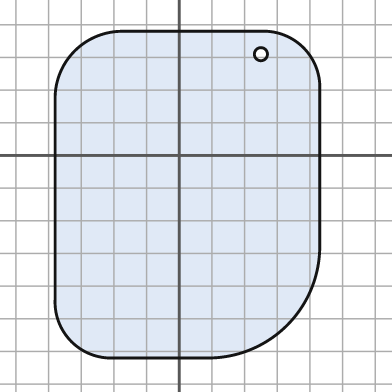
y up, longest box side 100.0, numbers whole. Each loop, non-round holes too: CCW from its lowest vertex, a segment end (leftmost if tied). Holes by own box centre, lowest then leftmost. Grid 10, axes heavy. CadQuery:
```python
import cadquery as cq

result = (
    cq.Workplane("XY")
    .moveTo(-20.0, -62.0)
    .lineTo(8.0, -62.0)
    .threePointArc((33.0, -52.0), (43.0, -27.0))
    .lineTo(43.0, 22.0)
    .threePointArc((38.0, 33.0), (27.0, 38.0))
    .lineTo(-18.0, 38.0)
    .threePointArc((-32.0, 32.0), (-38.0, 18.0))
    .lineTo(-38.0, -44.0)
    .threePointArc((-33.0, -57.0), (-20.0, -62.0))
    .close()
    .moveTo(25.0, 31.0)
    .circle(2.0)
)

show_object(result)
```